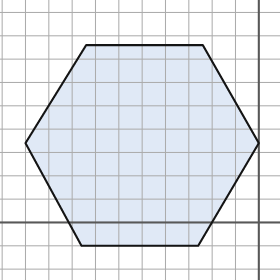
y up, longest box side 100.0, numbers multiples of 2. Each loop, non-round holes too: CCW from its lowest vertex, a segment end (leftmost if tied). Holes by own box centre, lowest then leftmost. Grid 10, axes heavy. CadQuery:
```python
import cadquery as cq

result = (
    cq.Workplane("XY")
    .moveTo(-76.0, -10.0)
    .lineTo(-26.0, -10.0)
    .lineTo(0.0, 34.0)
    .lineTo(-24.0, 76.0)
    .lineTo(-74.0, 76.0)
    .lineTo(-100.0, 34.0)
    .close()
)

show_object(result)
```